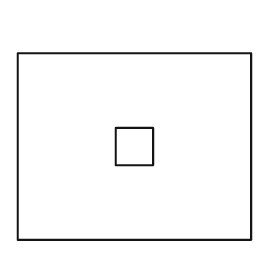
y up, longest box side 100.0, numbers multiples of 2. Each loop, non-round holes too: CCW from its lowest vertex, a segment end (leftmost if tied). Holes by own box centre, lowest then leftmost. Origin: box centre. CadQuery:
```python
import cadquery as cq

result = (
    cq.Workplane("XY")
    .moveTo(-50.0, -40.0)
    .lineTo(50.0, -40.0)
    .lineTo(50.0, 40.0)
    .lineTo(-50.0, 40.0)
    .close()
    .moveTo(-8.0, -8.0)
    .lineTo(8.0, -8.0)
    .lineTo(8.0, 8.0)
    .lineTo(-8.0, 8.0)
    .close()
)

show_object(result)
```